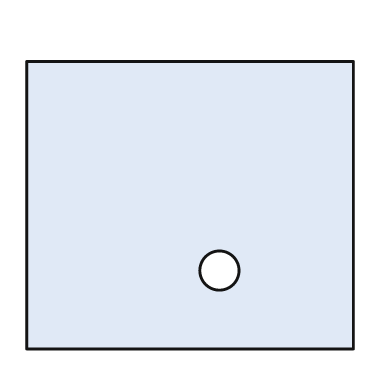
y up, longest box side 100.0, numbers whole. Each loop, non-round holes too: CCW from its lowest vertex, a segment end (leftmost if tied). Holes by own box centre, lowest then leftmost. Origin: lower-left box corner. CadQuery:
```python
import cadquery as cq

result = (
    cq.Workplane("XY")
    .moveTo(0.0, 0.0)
    .lineTo(100.0, 0.0)
    .lineTo(100.0, 88.0)
    .lineTo(0.0, 88.0)
    .close()
    .moveTo(59.0, 24.0)
    .circle(6.0)
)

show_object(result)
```